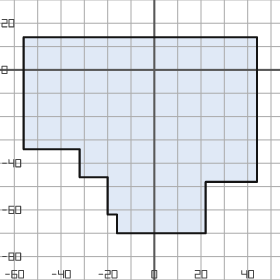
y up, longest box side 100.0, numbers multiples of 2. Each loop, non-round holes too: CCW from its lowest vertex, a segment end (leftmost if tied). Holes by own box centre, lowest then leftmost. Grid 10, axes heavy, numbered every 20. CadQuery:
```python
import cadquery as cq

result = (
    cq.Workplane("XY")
    .moveTo(-16.0, -70.0)
    .lineTo(22.0, -70.0)
    .lineTo(22.0, -48.0)
    .lineTo(44.0, -48.0)
    .lineTo(44.0, 14.0)
    .lineTo(-56.0, 14.0)
    .lineTo(-56.0, -34.0)
    .lineTo(-32.0, -34.0)
    .lineTo(-32.0, -46.0)
    .lineTo(-20.0, -46.0)
    .lineTo(-20.0, -62.0)
    .lineTo(-16.0, -62.0)
    .close()
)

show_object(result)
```